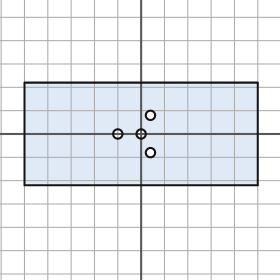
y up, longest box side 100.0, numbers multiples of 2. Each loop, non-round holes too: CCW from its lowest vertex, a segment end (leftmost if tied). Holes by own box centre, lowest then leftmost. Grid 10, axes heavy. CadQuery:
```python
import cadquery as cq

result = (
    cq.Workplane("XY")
    .moveTo(-50.0, -22.0)
    .lineTo(50.0, -22.0)
    .lineTo(50.0, 22.0)
    .lineTo(-50.0, 22.0)
    .close()
    .moveTo(4.0, -8.0)
    .circle(2.0)
    .moveTo(-10.0, 0.0)
    .circle(2.0)
    .moveTo(0.0, 0.0)
    .circle(2.0)
    .moveTo(4.0, 8.0)
    .circle(2.0)
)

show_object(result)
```